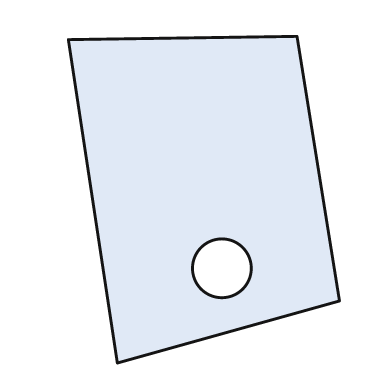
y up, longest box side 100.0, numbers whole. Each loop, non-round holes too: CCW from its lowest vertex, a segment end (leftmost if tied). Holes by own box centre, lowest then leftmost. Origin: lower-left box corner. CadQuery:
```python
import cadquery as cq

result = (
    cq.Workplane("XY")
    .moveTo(15.0, 0.0)
    .lineTo(83.0, 19.0)
    .lineTo(70.0, 100.0)
    .lineTo(0.0, 99.0)
    .close()
    .moveTo(47.0, 29.0)
    .circle(9.0)
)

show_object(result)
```